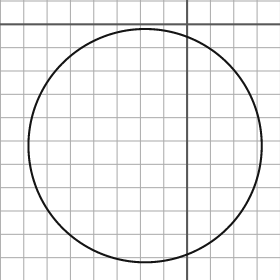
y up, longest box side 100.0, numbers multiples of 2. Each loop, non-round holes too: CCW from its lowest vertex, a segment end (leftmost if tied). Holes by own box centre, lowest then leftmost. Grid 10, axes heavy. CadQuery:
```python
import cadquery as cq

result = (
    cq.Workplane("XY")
    .moveTo(-18.0, -52.0)
    .circle(50.0)
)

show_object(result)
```